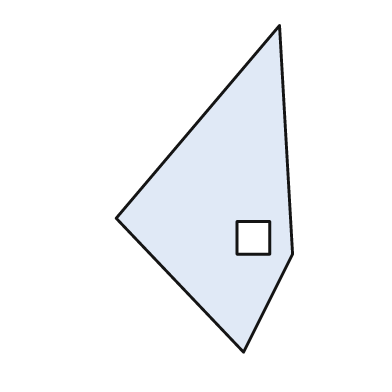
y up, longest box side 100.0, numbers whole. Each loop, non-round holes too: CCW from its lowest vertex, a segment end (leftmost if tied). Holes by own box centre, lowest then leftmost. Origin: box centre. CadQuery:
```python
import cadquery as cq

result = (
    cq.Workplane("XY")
    .moveTo(12.0, -50.0)
    .lineTo(27.0, -20.0)
    .lineTo(23.0, 50.0)
    .lineTo(-27.0, -9.0)
    .close()
    .moveTo(10.0, -20.0)
    .lineTo(20.0, -20.0)
    .lineTo(20.0, -10.0)
    .lineTo(10.0, -10.0)
    .close()
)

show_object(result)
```